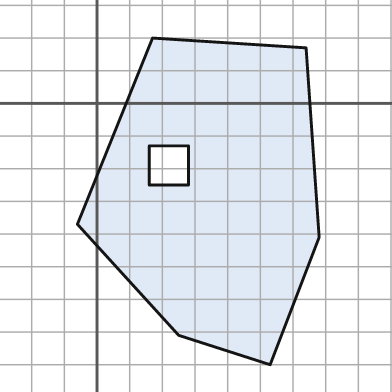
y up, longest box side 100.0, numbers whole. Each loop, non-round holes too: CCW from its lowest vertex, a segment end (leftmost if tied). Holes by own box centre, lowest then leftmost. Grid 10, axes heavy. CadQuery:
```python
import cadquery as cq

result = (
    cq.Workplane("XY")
    .moveTo(53.0, -80.0)
    .lineTo(68.0, -41.0)
    .lineTo(64.0, 17.0)
    .lineTo(17.0, 20.0)
    .lineTo(-6.0, -37.0)
    .lineTo(25.0, -71.0)
    .close()
    .moveTo(16.0, -25.0)
    .lineTo(28.0, -25.0)
    .lineTo(28.0, -13.0)
    .lineTo(16.0, -13.0)
    .close()
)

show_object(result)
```